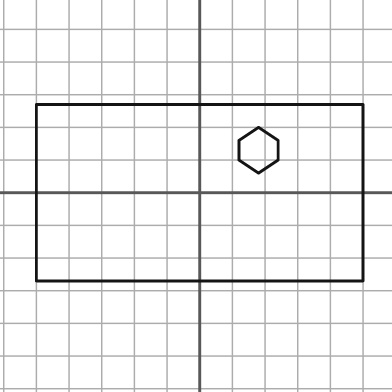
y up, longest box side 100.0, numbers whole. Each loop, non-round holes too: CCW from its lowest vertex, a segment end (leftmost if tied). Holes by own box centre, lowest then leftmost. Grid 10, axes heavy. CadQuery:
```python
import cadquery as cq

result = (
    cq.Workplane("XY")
    .moveTo(-50.0, -27.0)
    .lineTo(50.0, -27.0)
    .lineTo(50.0, 27.0)
    .lineTo(-50.0, 27.0)
    .close()
    .moveTo(18.0, 6.0)
    .lineTo(24.0, 10.0)
    .lineTo(24.0, 16.0)
    .lineTo(18.0, 20.0)
    .lineTo(12.0, 16.0)
    .lineTo(12.0, 10.0)
    .close()
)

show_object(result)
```